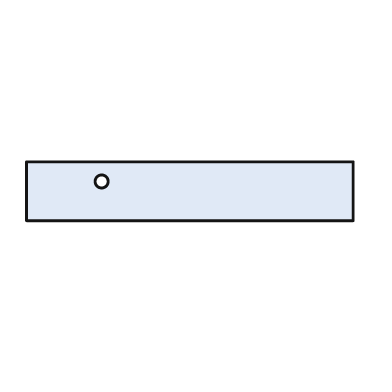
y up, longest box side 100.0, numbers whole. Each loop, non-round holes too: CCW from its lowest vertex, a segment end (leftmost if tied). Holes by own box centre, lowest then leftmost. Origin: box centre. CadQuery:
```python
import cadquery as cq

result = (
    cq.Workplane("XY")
    .moveTo(-50.0, -9.0)
    .lineTo(50.0, -9.0)
    .lineTo(50.0, 9.0)
    .lineTo(-50.0, 9.0)
    .close()
    .moveTo(-27.0, 3.0)
    .circle(2.0)
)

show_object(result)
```